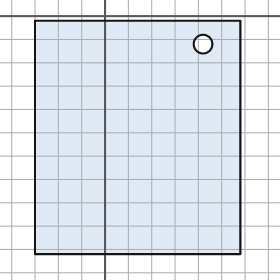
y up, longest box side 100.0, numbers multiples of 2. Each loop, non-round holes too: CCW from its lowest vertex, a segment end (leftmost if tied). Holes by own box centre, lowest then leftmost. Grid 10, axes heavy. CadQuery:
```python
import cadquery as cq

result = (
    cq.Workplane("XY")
    .moveTo(-30.0, -102.0)
    .lineTo(58.0, -102.0)
    .lineTo(58.0, -2.0)
    .lineTo(-30.0, -2.0)
    .close()
    .moveTo(42.0, -12.0)
    .circle(4.0)
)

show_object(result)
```